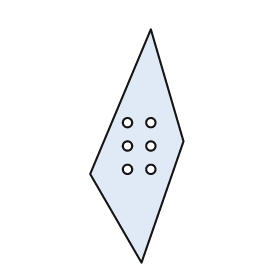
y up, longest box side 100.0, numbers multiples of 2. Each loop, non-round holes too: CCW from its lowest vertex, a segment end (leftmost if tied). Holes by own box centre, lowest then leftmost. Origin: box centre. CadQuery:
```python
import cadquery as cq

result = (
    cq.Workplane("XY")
    .moveTo(2.0, -50.0)
    .lineTo(20.0, 2.0)
    .lineTo(6.0, 50.0)
    .lineTo(-20.0, -12.0)
    .close()
    .moveTo(-4.0, -10.0)
    .circle(2.0)
    .moveTo(6.0, -10.0)
    .circle(2.0)
    .moveTo(-4.0, 0.0)
    .circle(2.0)
    .moveTo(6.0, 0.0)
    .circle(2.0)
    .moveTo(-4.0, 10.0)
    .circle(2.0)
    .moveTo(6.0, 10.0)
    .circle(2.0)
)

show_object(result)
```